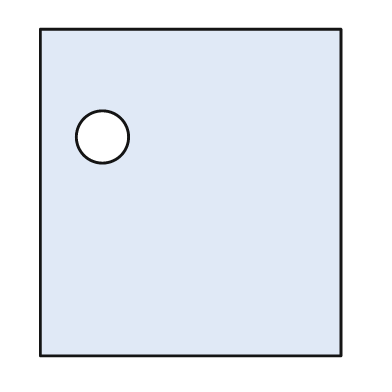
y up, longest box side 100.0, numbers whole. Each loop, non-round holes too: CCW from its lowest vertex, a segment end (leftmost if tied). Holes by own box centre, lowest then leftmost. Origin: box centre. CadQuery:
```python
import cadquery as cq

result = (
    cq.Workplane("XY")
    .moveTo(-46.0, -50.0)
    .lineTo(46.0, -50.0)
    .lineTo(46.0, 50.0)
    .lineTo(-46.0, 50.0)
    .close()
    .moveTo(-27.0, 17.0)
    .circle(8.0)
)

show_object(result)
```